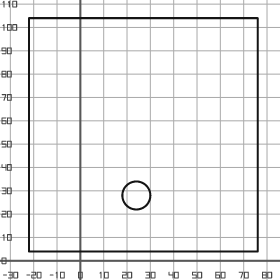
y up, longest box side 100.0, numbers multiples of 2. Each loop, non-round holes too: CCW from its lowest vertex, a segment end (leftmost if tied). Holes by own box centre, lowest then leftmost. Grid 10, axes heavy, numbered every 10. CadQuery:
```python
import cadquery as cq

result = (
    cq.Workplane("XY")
    .moveTo(-22.0, 4.0)
    .lineTo(76.0, 4.0)
    .lineTo(76.0, 104.0)
    .lineTo(-22.0, 104.0)
    .close()
    .moveTo(24.0, 28.0)
    .circle(6.0)
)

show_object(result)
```